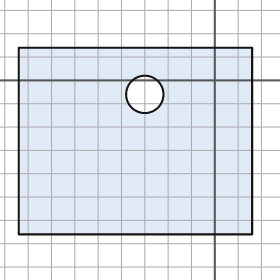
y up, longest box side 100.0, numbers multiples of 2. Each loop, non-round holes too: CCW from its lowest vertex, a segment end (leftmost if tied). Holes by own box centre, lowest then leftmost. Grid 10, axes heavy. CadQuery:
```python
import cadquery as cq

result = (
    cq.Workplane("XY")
    .moveTo(-84.0, -66.0)
    .lineTo(16.0, -66.0)
    .lineTo(16.0, 14.0)
    .lineTo(-84.0, 14.0)
    .close()
    .moveTo(-30.0, -6.0)
    .circle(8.0)
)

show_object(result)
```